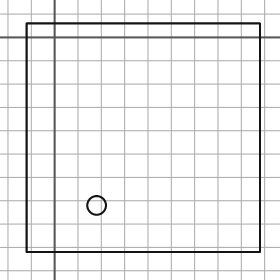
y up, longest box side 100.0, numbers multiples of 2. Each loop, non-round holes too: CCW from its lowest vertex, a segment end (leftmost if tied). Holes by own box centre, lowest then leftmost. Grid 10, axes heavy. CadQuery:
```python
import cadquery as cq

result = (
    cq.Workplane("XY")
    .moveTo(-12.0, -92.0)
    .lineTo(88.0, -92.0)
    .lineTo(88.0, 6.0)
    .lineTo(-12.0, 6.0)
    .close()
    .moveTo(18.0, -72.0)
    .circle(4.0)
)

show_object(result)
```